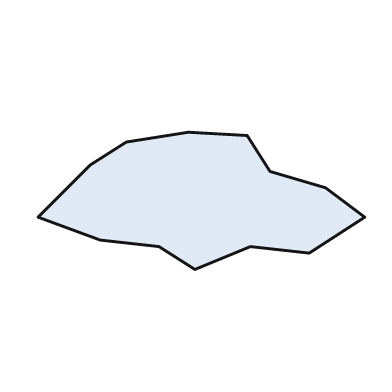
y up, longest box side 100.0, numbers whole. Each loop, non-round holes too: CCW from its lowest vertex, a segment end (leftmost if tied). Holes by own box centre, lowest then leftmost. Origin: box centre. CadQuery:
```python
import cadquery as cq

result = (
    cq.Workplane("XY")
    .moveTo(-2.0, -21.0)
    .lineTo(15.0, -14.0)
    .lineTo(33.0, -16.0)
    .lineTo(50.0, -5.0)
    .lineTo(38.0, 4.0)
    .lineTo(21.0, 9.0)
    .lineTo(14.0, 20.0)
    .lineTo(-4.0, 21.0)
    .lineTo(-23.0, 18.0)
    .lineTo(-34.0, 11.0)
    .lineTo(-50.0, -5.0)
    .lineTo(-31.0, -12.0)
    .lineTo(-13.0, -14.0)
    .close()
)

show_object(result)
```